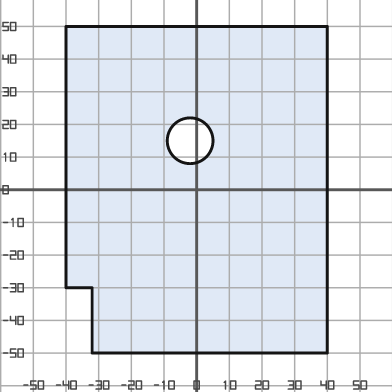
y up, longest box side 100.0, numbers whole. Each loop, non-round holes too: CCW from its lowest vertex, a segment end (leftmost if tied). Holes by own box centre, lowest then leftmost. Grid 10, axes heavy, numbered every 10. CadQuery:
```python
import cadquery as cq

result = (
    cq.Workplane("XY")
    .moveTo(-32.0, -50.0)
    .lineTo(40.0, -50.0)
    .lineTo(40.0, 50.0)
    .lineTo(-40.0, 50.0)
    .lineTo(-40.0, -30.0)
    .lineTo(-32.0, -30.0)
    .close()
    .moveTo(-2.0, 15.0)
    .circle(7.0)
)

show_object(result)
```